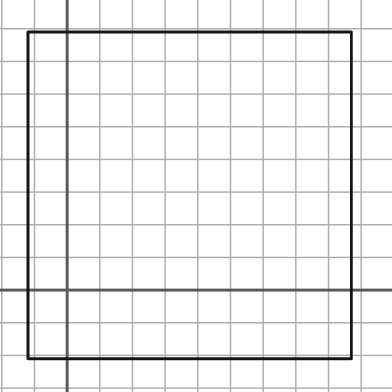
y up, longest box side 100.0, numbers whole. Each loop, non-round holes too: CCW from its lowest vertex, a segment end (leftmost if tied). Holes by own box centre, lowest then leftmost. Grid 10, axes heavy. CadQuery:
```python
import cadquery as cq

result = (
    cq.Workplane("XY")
    .moveTo(-12.0, -21.0)
    .lineTo(87.0, -21.0)
    .lineTo(87.0, 79.0)
    .lineTo(-12.0, 79.0)
    .close()
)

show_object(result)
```